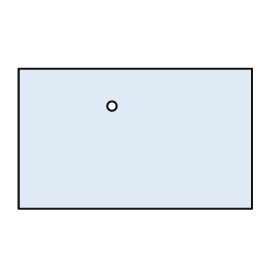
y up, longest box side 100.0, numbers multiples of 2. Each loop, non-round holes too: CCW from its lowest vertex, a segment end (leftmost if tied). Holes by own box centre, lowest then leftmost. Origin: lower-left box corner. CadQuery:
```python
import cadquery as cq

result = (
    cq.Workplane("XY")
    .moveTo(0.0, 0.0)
    .lineTo(100.0, 0.0)
    .lineTo(100.0, 60.0)
    .lineTo(0.0, 60.0)
    .close()
    .moveTo(40.0, 44.0)
    .circle(2.0)
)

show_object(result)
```